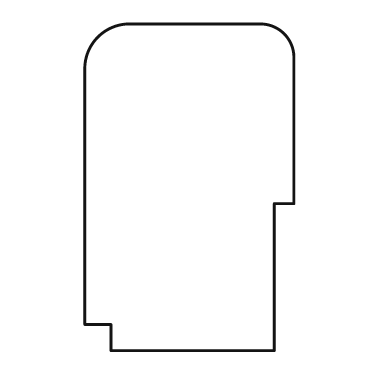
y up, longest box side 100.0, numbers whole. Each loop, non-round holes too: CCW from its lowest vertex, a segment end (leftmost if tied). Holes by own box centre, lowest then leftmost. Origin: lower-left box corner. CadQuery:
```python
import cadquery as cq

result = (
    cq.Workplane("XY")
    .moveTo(8.0, 0.0)
    .lineTo(58.0, 0.0)
    .lineTo(58.0, 45.0)
    .lineTo(64.0, 45.0)
    .lineTo(64.0, 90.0)
    .threePointArc((61.0, 97.0), (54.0, 100.0))
    .lineTo(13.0, 100.0)
    .threePointArc((4.0, 96.0), (0.0, 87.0))
    .lineTo(0.0, 8.0)
    .lineTo(8.0, 8.0)
    .close()
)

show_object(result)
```